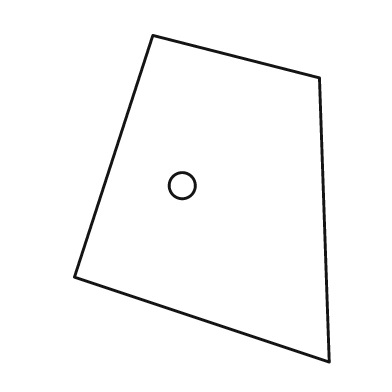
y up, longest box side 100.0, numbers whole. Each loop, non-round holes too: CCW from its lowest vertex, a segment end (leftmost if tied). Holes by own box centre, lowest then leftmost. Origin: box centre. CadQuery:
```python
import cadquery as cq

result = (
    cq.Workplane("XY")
    .moveTo(39.0, -50.0)
    .lineTo(36.0, 37.0)
    .lineTo(-15.0, 50.0)
    .lineTo(-39.0, -24.0)
    .close()
    .moveTo(-6.0, 4.0)
    .circle(4.0)
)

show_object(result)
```